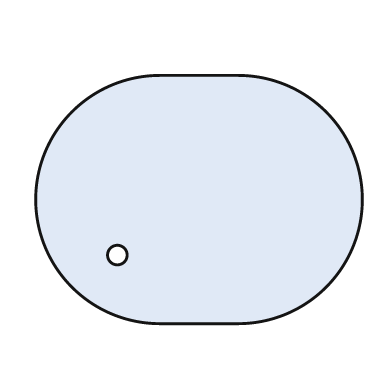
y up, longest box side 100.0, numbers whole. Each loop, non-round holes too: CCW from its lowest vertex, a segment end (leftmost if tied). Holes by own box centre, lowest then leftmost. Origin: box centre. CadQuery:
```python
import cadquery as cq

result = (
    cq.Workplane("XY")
    .moveTo(-12.0, -38.0)
    .lineTo(12.0, -38.0)
    .threePointArc((50.0, 0.0), (12.0, 38.0))
    .lineTo(-12.0, 38.0)
    .threePointArc((-50.0, 0.0), (-12.0, -38.0))
    .close()
    .moveTo(-25.0, -17.0)
    .circle(3.0)
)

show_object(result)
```